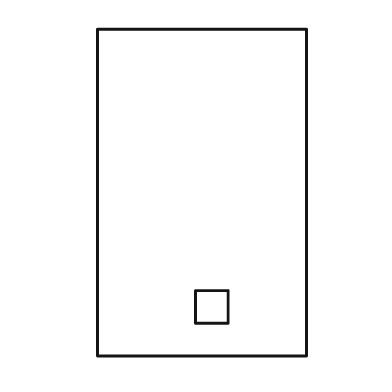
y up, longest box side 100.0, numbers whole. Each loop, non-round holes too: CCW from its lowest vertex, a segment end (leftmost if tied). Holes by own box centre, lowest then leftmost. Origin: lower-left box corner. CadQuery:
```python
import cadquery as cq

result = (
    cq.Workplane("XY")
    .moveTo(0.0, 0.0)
    .lineTo(64.0, 0.0)
    .lineTo(64.0, 100.0)
    .lineTo(0.0, 100.0)
    .close()
    .moveTo(30.0, 10.0)
    .lineTo(40.0, 10.0)
    .lineTo(40.0, 20.0)
    .lineTo(30.0, 20.0)
    .close()
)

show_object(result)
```